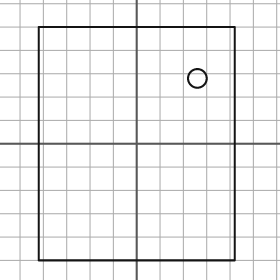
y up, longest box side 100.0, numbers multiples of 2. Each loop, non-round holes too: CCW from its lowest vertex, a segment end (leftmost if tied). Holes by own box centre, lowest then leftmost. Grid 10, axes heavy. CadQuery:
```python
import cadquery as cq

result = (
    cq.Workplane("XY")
    .moveTo(-42.0, -50.0)
    .lineTo(42.0, -50.0)
    .lineTo(42.0, 50.0)
    .lineTo(-42.0, 50.0)
    .close()
    .moveTo(26.0, 28.0)
    .circle(4.0)
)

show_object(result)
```